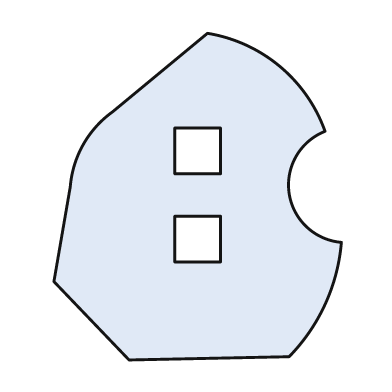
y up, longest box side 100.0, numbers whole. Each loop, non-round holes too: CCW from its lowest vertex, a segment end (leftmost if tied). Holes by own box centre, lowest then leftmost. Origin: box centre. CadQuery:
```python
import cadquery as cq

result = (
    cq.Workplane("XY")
    .moveTo(-21.0, -50.0)
    .lineTo(28.0, -49.0)
    .threePointArc((39.0, -33.0), (44.0, -14.0))
    .threePointArc((28.0, 1.0), (39.0, 20.0))
    .threePointArc((25.0, 40.0), (3.0, 50.0))
    .lineTo(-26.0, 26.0)
    .threePointArc((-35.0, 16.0), (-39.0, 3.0))
    .lineTo(-44.0, -26.0)
    .close()
    .moveTo(-7.0, -20.0)
    .lineTo(7.0, -20.0)
    .lineTo(7.0, -6.0)
    .lineTo(-7.0, -6.0)
    .close()
    .moveTo(-7.0, 7.0)
    .lineTo(7.0, 7.0)
    .lineTo(7.0, 21.0)
    .lineTo(-7.0, 21.0)
    .close()
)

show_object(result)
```